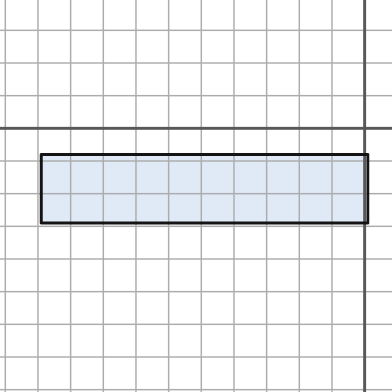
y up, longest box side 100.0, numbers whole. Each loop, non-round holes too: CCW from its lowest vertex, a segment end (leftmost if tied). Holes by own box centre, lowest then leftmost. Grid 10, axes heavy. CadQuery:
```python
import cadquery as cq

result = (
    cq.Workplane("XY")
    .moveTo(-99.0, -29.0)
    .lineTo(1.0, -29.0)
    .lineTo(1.0, -8.0)
    .lineTo(-99.0, -8.0)
    .close()
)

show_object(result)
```